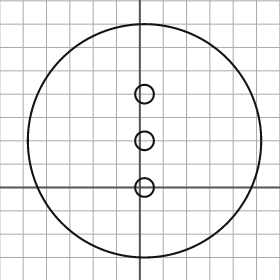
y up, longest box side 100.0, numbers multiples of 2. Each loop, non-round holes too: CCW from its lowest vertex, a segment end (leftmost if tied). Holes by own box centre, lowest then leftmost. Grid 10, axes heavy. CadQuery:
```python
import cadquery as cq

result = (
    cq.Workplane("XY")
    .moveTo(2.0, 20.0)
    .circle(50.0)
    .moveTo(2.0, 0.0)
    .circle(4.0)
    .moveTo(2.0, 20.0)
    .circle(4.0)
    .moveTo(2.0, 40.0)
    .circle(4.0)
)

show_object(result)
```